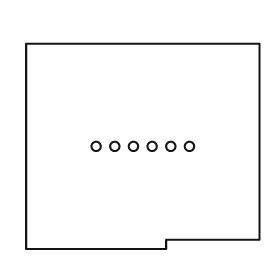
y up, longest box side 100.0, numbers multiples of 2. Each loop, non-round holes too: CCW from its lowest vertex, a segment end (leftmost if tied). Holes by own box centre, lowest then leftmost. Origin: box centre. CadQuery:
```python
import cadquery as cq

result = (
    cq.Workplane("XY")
    .moveTo(-50.0, -44.0)
    .lineTo(10.0, -44.0)
    .lineTo(10.0, -40.0)
    .lineTo(50.0, -40.0)
    .lineTo(50.0, 44.0)
    .lineTo(-50.0, 44.0)
    .close()
    .moveTo(-20.0, 0.0)
    .circle(2.0)
    .moveTo(-12.0, 0.0)
    .circle(2.0)
    .moveTo(-4.0, 0.0)
    .circle(2.0)
    .moveTo(4.0, 0.0)
    .circle(2.0)
    .moveTo(12.0, 0.0)
    .circle(2.0)
    .moveTo(20.0, 0.0)
    .circle(2.0)
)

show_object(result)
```